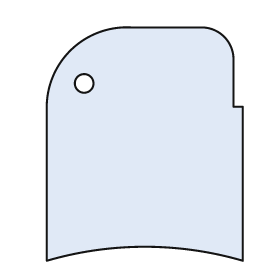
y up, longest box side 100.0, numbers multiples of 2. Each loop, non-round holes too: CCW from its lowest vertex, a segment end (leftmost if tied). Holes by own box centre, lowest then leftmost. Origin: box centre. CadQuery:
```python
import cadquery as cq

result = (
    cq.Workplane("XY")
    .moveTo(-42.0, -50.0)
    .threePointArc((0.0, -44.0), (42.0, -50.0))
    .lineTo(42.0, 16.0)
    .lineTo(38.0, 16.0)
    .lineTo(38.0, 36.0)
    .threePointArc((34.0, 46.0), (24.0, 50.0))
    .lineTo(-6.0, 50.0)
    .threePointArc((-32.0, 40.0), (-42.0, 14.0))
    .close()
    .moveTo(-26.0, 26.0)
    .circle(4.0)
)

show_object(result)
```